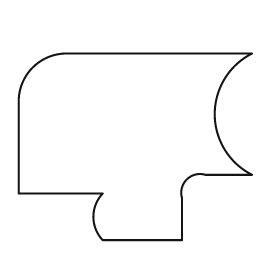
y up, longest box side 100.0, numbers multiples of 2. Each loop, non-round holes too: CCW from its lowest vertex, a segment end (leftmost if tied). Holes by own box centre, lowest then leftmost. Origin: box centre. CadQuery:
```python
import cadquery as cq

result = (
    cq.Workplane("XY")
    .moveTo(-14.0, -40.0)
    .lineTo(20.0, -40.0)
    .lineTo(20.0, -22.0)
    .threePointArc((22.0, -14.0), (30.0, -12.0))
    .lineTo(50.0, -12.0)
    .threePointArc((34.0, 14.0), (50.0, 40.0))
    .lineTo(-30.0, 40.0)
    .threePointArc((-44.0, 34.0), (-50.0, 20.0))
    .lineTo(-50.0, -20.0)
    .lineTo(-14.0, -20.0)
    .threePointArc((-18.0, -30.0), (-14.0, -40.0))
    .close()
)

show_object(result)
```